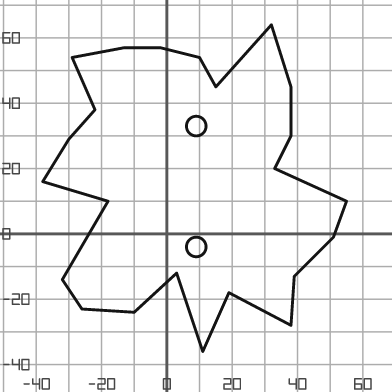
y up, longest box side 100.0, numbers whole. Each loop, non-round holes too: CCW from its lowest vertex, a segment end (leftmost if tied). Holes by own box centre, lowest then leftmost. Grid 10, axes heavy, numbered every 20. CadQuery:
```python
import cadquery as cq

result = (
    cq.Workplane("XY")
    .moveTo(11.0, -36.0)
    .lineTo(19.0, -18.0)
    .lineTo(38.0, -28.0)
    .lineTo(39.0, -13.0)
    .lineTo(51.0, -1.0)
    .lineTo(55.0, 10.0)
    .lineTo(33.0, 20.0)
    .lineTo(38.0, 30.0)
    .lineTo(38.0, 45.0)
    .lineTo(32.0, 64.0)
    .lineTo(15.0, 45.0)
    .lineTo(10.0, 54.0)
    .lineTo(-2.0, 57.0)
    .lineTo(-13.0, 57.0)
    .lineTo(-29.0, 54.0)
    .lineTo(-22.0, 38.0)
    .lineTo(-30.0, 29.0)
    .lineTo(-38.0, 16.0)
    .lineTo(-18.0, 10.0)
    .lineTo(-32.0, -14.0)
    .lineTo(-26.0, -23.0)
    .lineTo(-10.0, -24.0)
    .lineTo(3.0, -12.0)
    .close()
    .moveTo(9.0, -4.0)
    .circle(3.0)
    .moveTo(9.0, 33.0)
    .circle(3.0)
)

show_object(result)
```